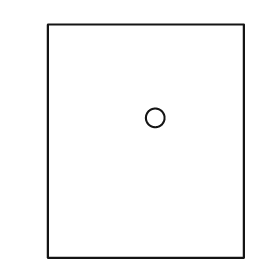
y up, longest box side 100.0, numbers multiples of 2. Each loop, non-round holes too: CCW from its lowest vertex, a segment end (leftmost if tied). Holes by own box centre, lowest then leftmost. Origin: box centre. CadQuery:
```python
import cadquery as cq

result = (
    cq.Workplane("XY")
    .moveTo(-42.0, -50.0)
    .lineTo(42.0, -50.0)
    .lineTo(42.0, 50.0)
    .lineTo(-42.0, 50.0)
    .close()
    .moveTo(4.0, 10.0)
    .circle(4.0)
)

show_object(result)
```